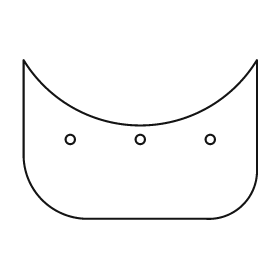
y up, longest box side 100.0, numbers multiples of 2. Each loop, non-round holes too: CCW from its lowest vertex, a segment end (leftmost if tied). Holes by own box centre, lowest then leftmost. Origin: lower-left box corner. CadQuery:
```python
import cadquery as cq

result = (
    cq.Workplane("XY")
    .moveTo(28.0, 0.0)
    .lineTo(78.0, 0.0)
    .threePointArc((94.0, 6.0), (100.0, 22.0))
    .lineTo(100.0, 68.0)
    .threePointArc((50.0, 40.0), (0.0, 68.0))
    .lineTo(0.0, 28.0)
    .threePointArc((8.0, 8.0), (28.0, 0.0))
    .close()
    .moveTo(20.0, 34.0)
    .circle(2.0)
    .moveTo(50.0, 34.0)
    .circle(2.0)
    .moveTo(80.0, 34.0)
    .circle(2.0)
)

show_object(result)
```